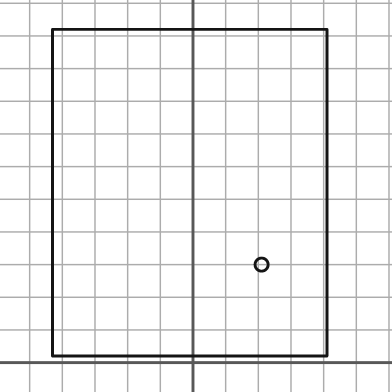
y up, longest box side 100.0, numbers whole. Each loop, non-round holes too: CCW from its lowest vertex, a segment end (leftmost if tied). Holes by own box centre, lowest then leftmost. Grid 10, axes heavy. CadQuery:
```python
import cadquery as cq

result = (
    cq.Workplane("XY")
    .moveTo(-43.0, 2.0)
    .lineTo(41.0, 2.0)
    .lineTo(41.0, 102.0)
    .lineTo(-43.0, 102.0)
    .close()
    .moveTo(21.0, 30.0)
    .circle(2.0)
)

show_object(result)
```